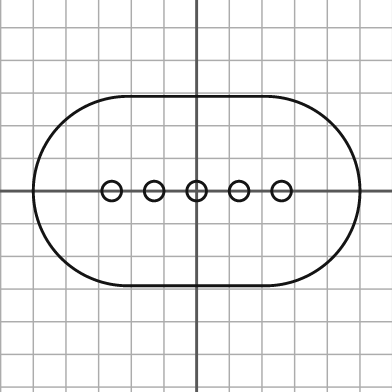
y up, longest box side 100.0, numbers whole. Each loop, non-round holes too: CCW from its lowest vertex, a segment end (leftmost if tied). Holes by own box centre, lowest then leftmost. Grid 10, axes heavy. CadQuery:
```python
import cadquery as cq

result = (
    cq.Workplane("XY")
    .moveTo(-21.0, -29.0)
    .lineTo(21.0, -29.0)
    .threePointArc((50.0, 0.0), (21.0, 29.0))
    .lineTo(-21.0, 29.0)
    .threePointArc((-50.0, 0.0), (-21.0, -29.0))
    .close()
    .moveTo(-26.0, 0.0)
    .circle(3.0)
    .moveTo(-13.0, 0.0)
    .circle(3.0)
    .moveTo(0.0, 0.0)
    .circle(3.0)
    .moveTo(13.0, 0.0)
    .circle(3.0)
    .moveTo(26.0, 0.0)
    .circle(3.0)
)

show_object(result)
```